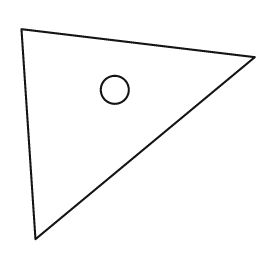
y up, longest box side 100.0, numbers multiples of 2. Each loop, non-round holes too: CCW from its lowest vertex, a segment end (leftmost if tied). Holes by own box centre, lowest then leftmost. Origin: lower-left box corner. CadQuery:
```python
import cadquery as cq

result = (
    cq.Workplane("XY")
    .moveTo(6.0, 0.0)
    .lineTo(100.0, 78.0)
    .lineTo(0.0, 90.0)
    .close()
    .moveTo(40.0, 64.0)
    .circle(6.0)
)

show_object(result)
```